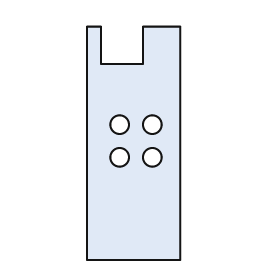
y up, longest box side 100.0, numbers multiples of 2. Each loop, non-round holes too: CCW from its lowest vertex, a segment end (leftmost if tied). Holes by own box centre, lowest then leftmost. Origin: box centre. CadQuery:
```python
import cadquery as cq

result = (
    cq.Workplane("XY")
    .moveTo(-20.0, -50.0)
    .lineTo(20.0, -50.0)
    .lineTo(20.0, 50.0)
    .lineTo(4.0, 50.0)
    .lineTo(4.0, 34.0)
    .lineTo(-14.0, 34.0)
    .lineTo(-14.0, 50.0)
    .lineTo(-20.0, 50.0)
    .close()
    .moveTo(-6.0, -6.0)
    .circle(4.0)
    .moveTo(8.0, -6.0)
    .circle(4.0)
    .moveTo(-6.0, 8.0)
    .circle(4.0)
    .moveTo(8.0, 8.0)
    .circle(4.0)
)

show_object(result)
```